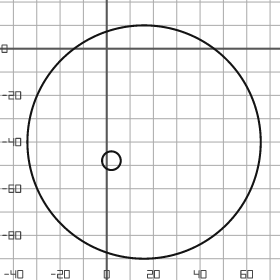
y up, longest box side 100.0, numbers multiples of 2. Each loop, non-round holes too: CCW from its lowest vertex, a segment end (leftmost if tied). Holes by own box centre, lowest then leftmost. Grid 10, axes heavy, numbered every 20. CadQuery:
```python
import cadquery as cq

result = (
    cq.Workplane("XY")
    .moveTo(16.0, -40.0)
    .circle(50.0)
    .moveTo(2.0, -48.0)
    .circle(4.0)
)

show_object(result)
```